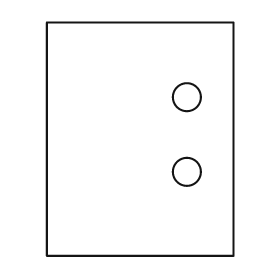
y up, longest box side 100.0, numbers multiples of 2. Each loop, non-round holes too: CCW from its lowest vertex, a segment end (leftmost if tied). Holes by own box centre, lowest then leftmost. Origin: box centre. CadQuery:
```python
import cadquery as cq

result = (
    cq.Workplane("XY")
    .moveTo(-40.0, -50.0)
    .lineTo(40.0, -50.0)
    .lineTo(40.0, 50.0)
    .lineTo(-40.0, 50.0)
    .close()
    .moveTo(20.0, -14.0)
    .circle(6.0)
    .moveTo(20.0, 18.0)
    .circle(6.0)
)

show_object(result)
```